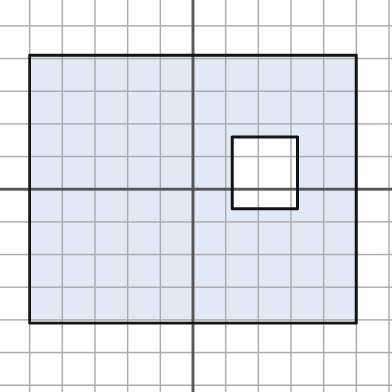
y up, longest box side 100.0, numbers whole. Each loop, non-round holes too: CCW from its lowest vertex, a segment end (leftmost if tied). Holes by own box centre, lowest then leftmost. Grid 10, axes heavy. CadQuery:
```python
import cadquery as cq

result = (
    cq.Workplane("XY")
    .moveTo(-50.0, -41.0)
    .lineTo(50.0, -41.0)
    .lineTo(50.0, 41.0)
    .lineTo(-50.0, 41.0)
    .close()
    .moveTo(12.0, -6.0)
    .lineTo(32.0, -6.0)
    .lineTo(32.0, 16.0)
    .lineTo(12.0, 16.0)
    .close()
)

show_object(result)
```